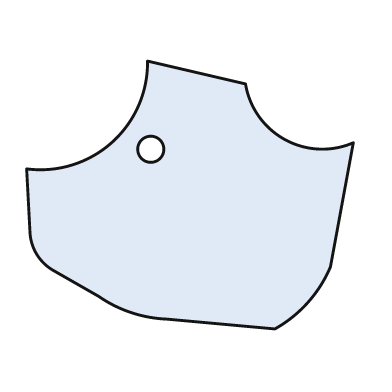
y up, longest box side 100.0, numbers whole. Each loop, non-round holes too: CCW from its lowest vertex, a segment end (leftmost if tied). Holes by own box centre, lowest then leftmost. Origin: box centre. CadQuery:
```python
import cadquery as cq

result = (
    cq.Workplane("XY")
    .moveTo(26.0, -41.0)
    .threePointArc((36.0, -33.0), (43.0, -22.0))
    .lineTo(50.0, 16.0)
    .threePointArc((29.0, 17.0), (17.0, 34.0))
    .lineTo(-13.0, 41.0)
    .threePointArc((-24.0, 16.0), (-50.0, 8.0))
    .lineTo(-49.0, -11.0)
    .threePointArc((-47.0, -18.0), (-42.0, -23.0))
    .lineTo(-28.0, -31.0)
    .threePointArc((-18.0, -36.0), (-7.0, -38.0))
    .close()
    .moveTo(-12.0, 14.0)
    .circle(4.0)
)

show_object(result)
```